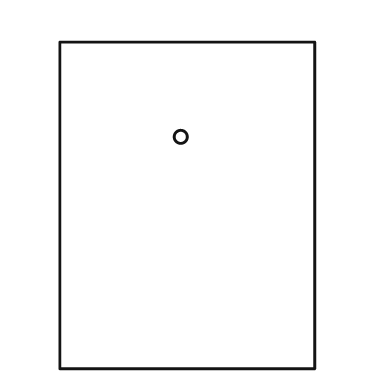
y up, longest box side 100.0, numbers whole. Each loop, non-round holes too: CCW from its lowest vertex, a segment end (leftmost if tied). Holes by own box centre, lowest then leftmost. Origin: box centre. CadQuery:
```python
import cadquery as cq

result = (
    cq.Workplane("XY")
    .moveTo(-39.0, -50.0)
    .lineTo(39.0, -50.0)
    .lineTo(39.0, 50.0)
    .lineTo(-39.0, 50.0)
    .close()
    .moveTo(-2.0, 21.0)
    .circle(2.0)
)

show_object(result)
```